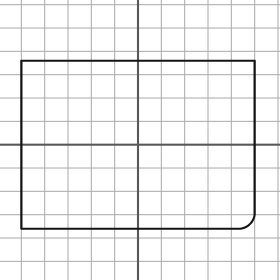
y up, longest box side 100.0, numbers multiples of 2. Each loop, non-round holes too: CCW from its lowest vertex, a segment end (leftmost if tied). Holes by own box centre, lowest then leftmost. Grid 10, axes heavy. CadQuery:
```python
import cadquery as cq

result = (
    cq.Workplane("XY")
    .moveTo(-50.0, -36.0)
    .lineTo(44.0, -36.0)
    .threePointArc((48.0, -34.0), (50.0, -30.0))
    .lineTo(50.0, 36.0)
    .lineTo(-50.0, 36.0)
    .close()
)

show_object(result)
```